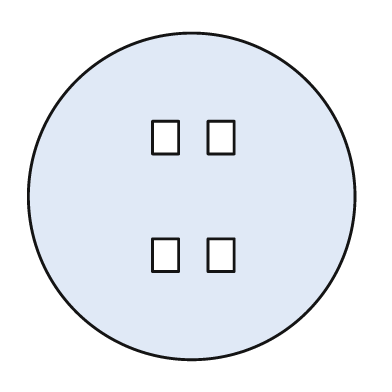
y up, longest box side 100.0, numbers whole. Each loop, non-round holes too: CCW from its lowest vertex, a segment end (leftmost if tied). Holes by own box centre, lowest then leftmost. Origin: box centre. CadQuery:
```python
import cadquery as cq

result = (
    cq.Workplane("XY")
    .moveTo(0.0, 0.0)
    .circle(50.0)
    .moveTo(-12.0, -23.0)
    .lineTo(-4.0, -23.0)
    .lineTo(-4.0, -13.0)
    .lineTo(-12.0, -13.0)
    .close()
    .moveTo(5.0, -23.0)
    .lineTo(13.0, -23.0)
    .lineTo(13.0, -13.0)
    .lineTo(5.0, -13.0)
    .close()
    .moveTo(-12.0, 13.0)
    .lineTo(-4.0, 13.0)
    .lineTo(-4.0, 23.0)
    .lineTo(-12.0, 23.0)
    .close()
    .moveTo(5.0, 13.0)
    .lineTo(13.0, 13.0)
    .lineTo(13.0, 23.0)
    .lineTo(5.0, 23.0)
    .close()
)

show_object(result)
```